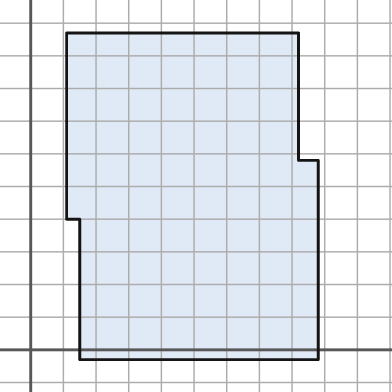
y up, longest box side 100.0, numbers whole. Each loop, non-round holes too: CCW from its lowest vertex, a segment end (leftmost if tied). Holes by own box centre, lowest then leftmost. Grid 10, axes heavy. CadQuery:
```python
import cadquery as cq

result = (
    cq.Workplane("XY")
    .moveTo(15.0, -3.0)
    .lineTo(88.0, -3.0)
    .lineTo(88.0, 58.0)
    .lineTo(82.0, 58.0)
    .lineTo(82.0, 97.0)
    .lineTo(11.0, 97.0)
    .lineTo(11.0, 40.0)
    .lineTo(15.0, 40.0)
    .close()
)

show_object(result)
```